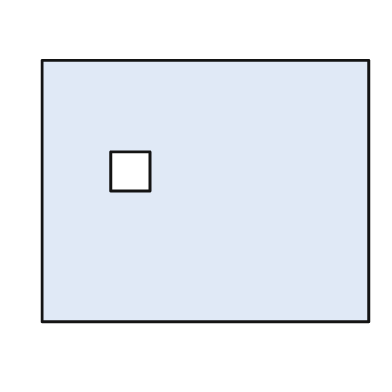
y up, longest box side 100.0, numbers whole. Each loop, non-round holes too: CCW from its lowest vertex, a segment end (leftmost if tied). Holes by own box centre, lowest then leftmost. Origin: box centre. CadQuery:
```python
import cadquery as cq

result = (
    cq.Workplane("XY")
    .moveTo(-50.0, -40.0)
    .lineTo(50.0, -40.0)
    .lineTo(50.0, 40.0)
    .lineTo(-50.0, 40.0)
    .close()
    .moveTo(-29.0, 0.0)
    .lineTo(-17.0, 0.0)
    .lineTo(-17.0, 12.0)
    .lineTo(-29.0, 12.0)
    .close()
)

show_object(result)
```